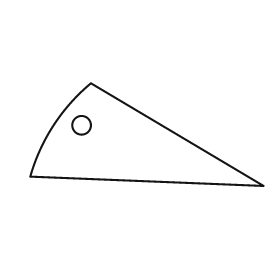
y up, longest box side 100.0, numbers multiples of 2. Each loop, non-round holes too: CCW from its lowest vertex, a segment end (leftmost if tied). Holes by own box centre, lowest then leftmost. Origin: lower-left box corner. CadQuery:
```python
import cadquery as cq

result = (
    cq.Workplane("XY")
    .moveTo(100.0, 0.0)
    .lineTo(26.0, 44.0)
    .threePointArc((10.0, 26.0), (0.0, 4.0))
    .close()
    .moveTo(22.0, 26.0)
    .circle(4.0)
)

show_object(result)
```